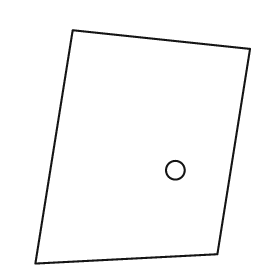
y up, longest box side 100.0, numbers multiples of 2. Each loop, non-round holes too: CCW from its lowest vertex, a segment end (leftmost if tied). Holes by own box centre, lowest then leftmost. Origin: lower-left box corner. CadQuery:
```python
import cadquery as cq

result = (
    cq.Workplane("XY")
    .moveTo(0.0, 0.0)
    .lineTo(78.0, 4.0)
    .lineTo(92.0, 92.0)
    .lineTo(16.0, 100.0)
    .close()
    .moveTo(60.0, 40.0)
    .circle(4.0)
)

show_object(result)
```